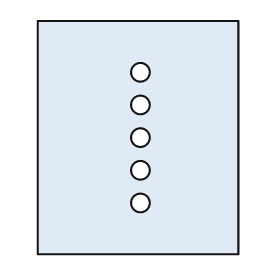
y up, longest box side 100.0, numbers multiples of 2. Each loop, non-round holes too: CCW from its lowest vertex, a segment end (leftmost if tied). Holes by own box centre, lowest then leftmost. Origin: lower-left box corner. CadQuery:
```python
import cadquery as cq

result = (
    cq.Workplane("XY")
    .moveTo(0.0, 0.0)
    .lineTo(86.0, 0.0)
    .lineTo(86.0, 100.0)
    .lineTo(0.0, 100.0)
    .close()
    .moveTo(44.0, 22.0)
    .circle(4.0)
    .moveTo(44.0, 36.0)
    .circle(4.0)
    .moveTo(44.0, 50.0)
    .circle(4.0)
    .moveTo(44.0, 64.0)
    .circle(4.0)
    .moveTo(44.0, 78.0)
    .circle(4.0)
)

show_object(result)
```